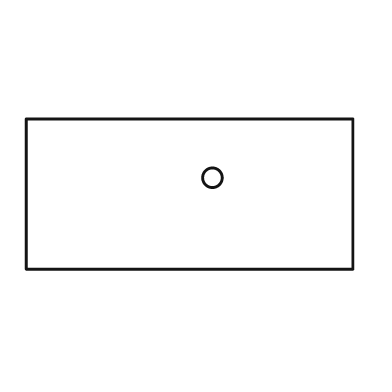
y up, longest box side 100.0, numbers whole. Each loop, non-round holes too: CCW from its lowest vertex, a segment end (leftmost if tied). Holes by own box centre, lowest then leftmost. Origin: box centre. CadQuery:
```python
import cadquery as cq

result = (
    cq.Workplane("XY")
    .moveTo(-50.0, -23.0)
    .lineTo(50.0, -23.0)
    .lineTo(50.0, 23.0)
    .lineTo(-50.0, 23.0)
    .close()
    .moveTo(7.0, 5.0)
    .circle(3.0)
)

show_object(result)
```